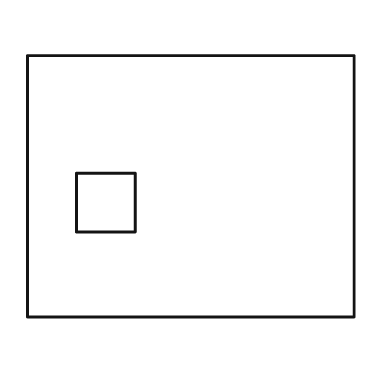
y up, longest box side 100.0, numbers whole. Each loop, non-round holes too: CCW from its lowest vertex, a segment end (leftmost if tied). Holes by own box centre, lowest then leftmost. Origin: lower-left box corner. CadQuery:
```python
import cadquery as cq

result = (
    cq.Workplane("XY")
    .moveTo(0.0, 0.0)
    .lineTo(100.0, 0.0)
    .lineTo(100.0, 80.0)
    .lineTo(0.0, 80.0)
    .close()
    .moveTo(15.0, 26.0)
    .lineTo(33.0, 26.0)
    .lineTo(33.0, 44.0)
    .lineTo(15.0, 44.0)
    .close()
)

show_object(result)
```